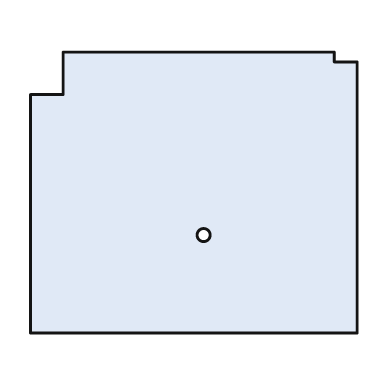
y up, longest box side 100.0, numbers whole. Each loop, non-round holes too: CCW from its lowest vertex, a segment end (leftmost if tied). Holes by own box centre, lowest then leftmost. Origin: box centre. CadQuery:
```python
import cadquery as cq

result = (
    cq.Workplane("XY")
    .moveTo(-50.0, -43.0)
    .lineTo(50.0, -43.0)
    .lineTo(50.0, 40.0)
    .lineTo(43.0, 40.0)
    .lineTo(43.0, 43.0)
    .lineTo(-40.0, 43.0)
    .lineTo(-40.0, 30.0)
    .lineTo(-50.0, 30.0)
    .close()
    .moveTo(3.0, -13.0)
    .circle(2.0)
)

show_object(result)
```